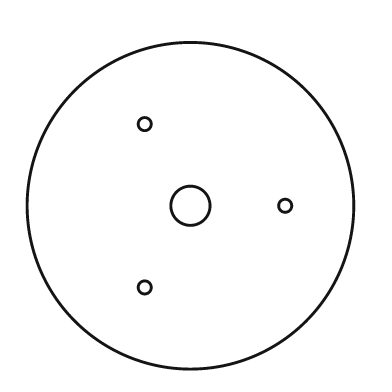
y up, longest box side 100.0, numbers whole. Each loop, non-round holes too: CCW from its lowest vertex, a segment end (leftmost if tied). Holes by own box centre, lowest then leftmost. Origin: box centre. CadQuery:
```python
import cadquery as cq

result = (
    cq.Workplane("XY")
    .moveTo(0.0, 0.0)
    .circle(50.0)
    .moveTo(-14.0, -25.0)
    .circle(2.0)
    .moveTo(0.0, 0.0)
    .circle(6.0)
    .moveTo(29.0, 0.0)
    .circle(2.0)
    .moveTo(-14.0, 25.0)
    .circle(2.0)
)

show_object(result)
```